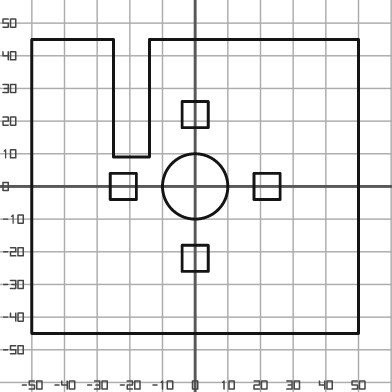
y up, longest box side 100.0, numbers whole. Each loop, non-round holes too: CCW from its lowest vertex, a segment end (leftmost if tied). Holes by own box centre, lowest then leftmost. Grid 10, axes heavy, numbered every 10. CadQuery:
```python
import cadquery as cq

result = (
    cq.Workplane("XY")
    .moveTo(-50.0, -45.0)
    .lineTo(50.0, -45.0)
    .lineTo(50.0, 45.0)
    .lineTo(-14.0, 45.0)
    .lineTo(-14.0, 9.0)
    .lineTo(-25.0, 9.0)
    .lineTo(-25.0, 45.0)
    .lineTo(-50.0, 45.0)
    .close()
    .moveTo(-4.0, -26.0)
    .lineTo(4.0, -26.0)
    .lineTo(4.0, -18.0)
    .lineTo(-4.0, -18.0)
    .close()
    .moveTo(-26.0, -4.0)
    .lineTo(-18.0, -4.0)
    .lineTo(-18.0, 4.0)
    .lineTo(-26.0, 4.0)
    .close()
    .moveTo(0.0, 0.0)
    .circle(10.0)
    .moveTo(18.0, -4.0)
    .lineTo(26.0, -4.0)
    .lineTo(26.0, 4.0)
    .lineTo(18.0, 4.0)
    .close()
    .moveTo(-4.0, 18.0)
    .lineTo(4.0, 18.0)
    .lineTo(4.0, 26.0)
    .lineTo(-4.0, 26.0)
    .close()
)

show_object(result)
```